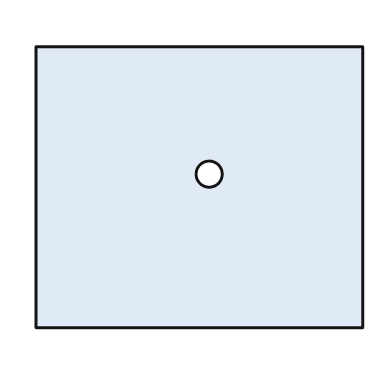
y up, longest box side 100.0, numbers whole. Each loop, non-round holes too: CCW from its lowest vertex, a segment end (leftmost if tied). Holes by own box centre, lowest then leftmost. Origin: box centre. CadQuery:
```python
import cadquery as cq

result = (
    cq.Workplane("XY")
    .moveTo(-50.0, -43.0)
    .lineTo(50.0, -43.0)
    .lineTo(50.0, 43.0)
    .lineTo(-50.0, 43.0)
    .close()
    .moveTo(3.0, 4.0)
    .circle(4.0)
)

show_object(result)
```